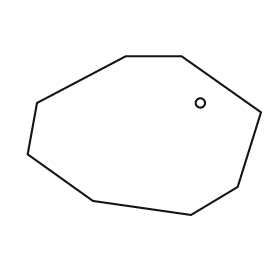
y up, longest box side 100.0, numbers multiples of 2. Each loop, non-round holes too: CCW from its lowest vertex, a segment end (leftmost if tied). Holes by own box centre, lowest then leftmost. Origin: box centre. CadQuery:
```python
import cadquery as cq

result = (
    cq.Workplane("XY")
    .moveTo(20.0, -34.0)
    .lineTo(40.0, -22.0)
    .lineTo(50.0, 10.0)
    .lineTo(16.0, 34.0)
    .lineTo(-8.0, 34.0)
    .lineTo(-46.0, 14.0)
    .lineTo(-50.0, -8.0)
    .lineTo(-22.0, -28.0)
    .close()
    .moveTo(24.0, 14.0)
    .circle(2.0)
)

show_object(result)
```